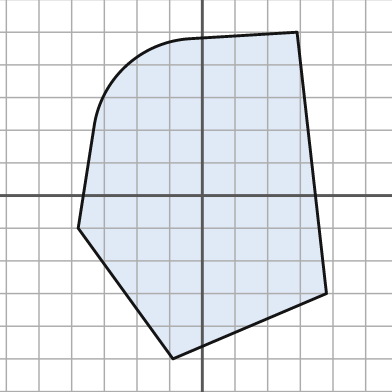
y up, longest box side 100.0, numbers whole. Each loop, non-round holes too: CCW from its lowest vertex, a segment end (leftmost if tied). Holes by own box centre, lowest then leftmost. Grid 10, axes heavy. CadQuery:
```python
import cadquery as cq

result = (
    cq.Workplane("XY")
    .moveTo(-9.0, -50.0)
    .lineTo(38.0, -30.0)
    .lineTo(29.0, 50.0)
    .lineTo(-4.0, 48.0)
    .threePointArc((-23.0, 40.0), (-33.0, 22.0))
    .lineTo(-38.0, -10.0)
    .close()
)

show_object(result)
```